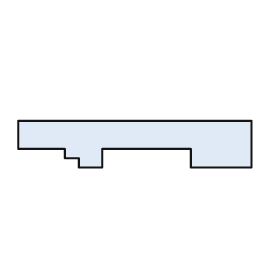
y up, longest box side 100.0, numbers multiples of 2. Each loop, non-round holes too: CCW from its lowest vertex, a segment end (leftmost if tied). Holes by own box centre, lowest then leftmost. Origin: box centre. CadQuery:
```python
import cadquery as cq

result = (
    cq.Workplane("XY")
    .moveTo(-24.0, -10.0)
    .lineTo(-14.0, -10.0)
    .lineTo(-14.0, -2.0)
    .lineTo(24.0, -2.0)
    .lineTo(24.0, -10.0)
    .lineTo(50.0, -10.0)
    .lineTo(50.0, 10.0)
    .lineTo(-50.0, 10.0)
    .lineTo(-50.0, -2.0)
    .lineTo(-30.0, -2.0)
    .lineTo(-30.0, -6.0)
    .lineTo(-24.0, -6.0)
    .close()
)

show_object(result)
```